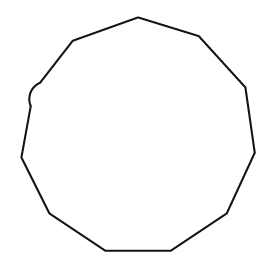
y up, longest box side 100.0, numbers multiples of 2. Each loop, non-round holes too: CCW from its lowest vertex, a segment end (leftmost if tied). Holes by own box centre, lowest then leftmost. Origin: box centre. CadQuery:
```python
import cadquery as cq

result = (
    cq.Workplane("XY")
    .moveTo(-14.0, -50.0)
    .lineTo(14.0, -50.0)
    .lineTo(38.0, -34.0)
    .lineTo(50.0, -8.0)
    .lineTo(46.0, 20.0)
    .lineTo(26.0, 42.0)
    .lineTo(0.0, 50.0)
    .lineTo(-28.0, 40.0)
    .lineTo(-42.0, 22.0)
    .threePointArc((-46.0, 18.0), (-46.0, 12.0))
    .lineTo(-50.0, -10.0)
    .lineTo(-38.0, -34.0)
    .close()
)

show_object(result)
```